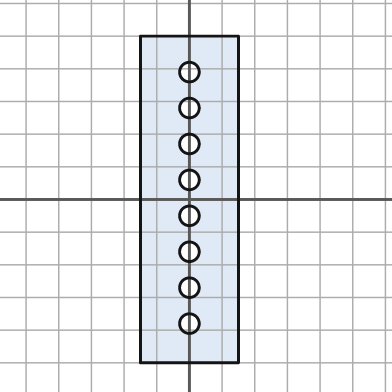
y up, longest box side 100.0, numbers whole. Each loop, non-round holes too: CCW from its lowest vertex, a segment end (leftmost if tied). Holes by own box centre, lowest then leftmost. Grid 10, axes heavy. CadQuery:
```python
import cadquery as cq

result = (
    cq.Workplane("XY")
    .moveTo(-15.0, -50.0)
    .lineTo(15.0, -50.0)
    .lineTo(15.0, 50.0)
    .lineTo(-15.0, 50.0)
    .close()
    .moveTo(0.0, -38.0)
    .circle(3.0)
    .moveTo(0.0, -27.0)
    .circle(3.0)
    .moveTo(0.0, -16.0)
    .circle(3.0)
    .moveTo(0.0, -5.0)
    .circle(3.0)
    .moveTo(0.0, 6.0)
    .circle(3.0)
    .moveTo(0.0, 17.0)
    .circle(3.0)
    .moveTo(0.0, 28.0)
    .circle(3.0)
    .moveTo(0.0, 39.0)
    .circle(3.0)
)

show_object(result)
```